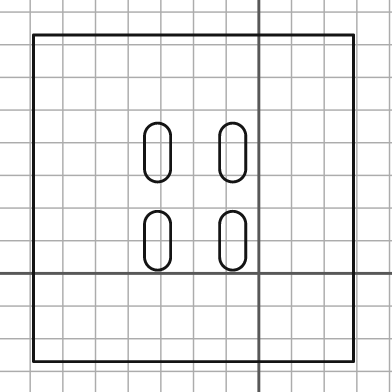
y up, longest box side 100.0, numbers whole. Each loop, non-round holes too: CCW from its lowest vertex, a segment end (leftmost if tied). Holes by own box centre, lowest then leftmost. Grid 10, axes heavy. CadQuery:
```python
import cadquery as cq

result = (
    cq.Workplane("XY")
    .moveTo(-69.0, -27.0)
    .lineTo(29.0, -27.0)
    .lineTo(29.0, 73.0)
    .lineTo(-69.0, 73.0)
    .close()
    .moveTo(-35.0, 5.0)
    .threePointArc((-31.0, 1.0), (-27.0, 5.0))
    .lineTo(-27.0, 15.0)
    .threePointArc((-31.0, 19.0), (-35.0, 15.0))
    .close()
    .moveTo(-12.0, 5.0)
    .threePointArc((-8.0, 1.0), (-4.0, 5.0))
    .lineTo(-4.0, 15.0)
    .threePointArc((-8.0, 19.0), (-12.0, 15.0))
    .close()
    .moveTo(-35.0, 32.0)
    .threePointArc((-31.0, 28.0), (-27.0, 32.0))
    .lineTo(-27.0, 42.0)
    .threePointArc((-31.0, 46.0), (-35.0, 42.0))
    .close()
    .moveTo(-12.0, 32.0)
    .threePointArc((-8.0, 28.0), (-4.0, 32.0))
    .lineTo(-4.0, 42.0)
    .threePointArc((-8.0, 46.0), (-12.0, 42.0))
    .close()
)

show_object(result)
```